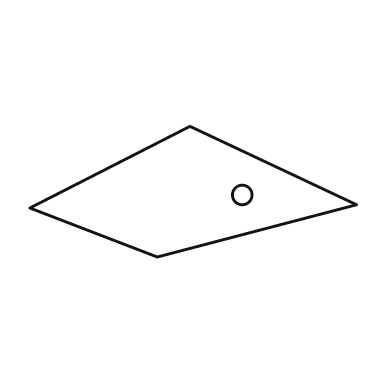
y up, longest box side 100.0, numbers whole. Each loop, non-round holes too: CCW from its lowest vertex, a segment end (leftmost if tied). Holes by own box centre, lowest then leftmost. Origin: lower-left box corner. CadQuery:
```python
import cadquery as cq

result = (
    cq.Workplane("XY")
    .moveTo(39.0, 0.0)
    .lineTo(100.0, 16.0)
    .lineTo(49.0, 40.0)
    .lineTo(0.0, 15.0)
    .close()
    .moveTo(65.0, 19.0)
    .circle(3.0)
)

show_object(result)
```